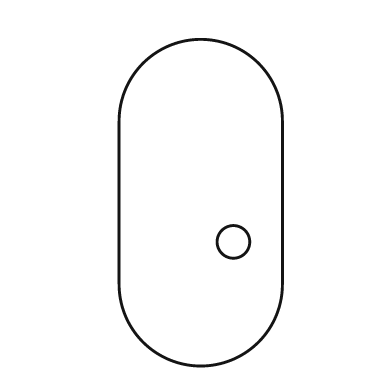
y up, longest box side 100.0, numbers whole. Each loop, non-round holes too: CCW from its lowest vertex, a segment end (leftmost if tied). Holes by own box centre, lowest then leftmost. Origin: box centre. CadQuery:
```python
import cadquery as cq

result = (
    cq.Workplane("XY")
    .moveTo(-25.0, -25.0)
    .threePointArc((0.0, -50.0), (25.0, -25.0))
    .lineTo(25.0, 25.0)
    .threePointArc((0.0, 50.0), (-25.0, 25.0))
    .close()
    .moveTo(10.0, -12.0)
    .circle(5.0)
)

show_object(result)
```